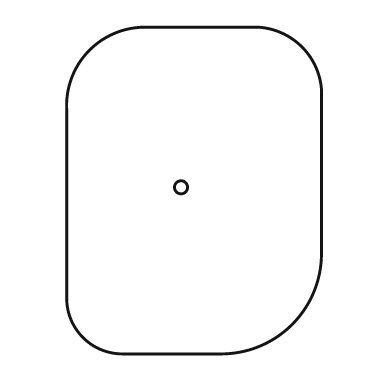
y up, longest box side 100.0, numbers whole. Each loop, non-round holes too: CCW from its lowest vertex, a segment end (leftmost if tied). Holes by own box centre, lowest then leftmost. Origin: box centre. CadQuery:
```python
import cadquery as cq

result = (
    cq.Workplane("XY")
    .moveTo(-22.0, -50.0)
    .lineTo(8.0, -50.0)
    .threePointArc((30.0, -41.0), (39.0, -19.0))
    .lineTo(39.0, 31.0)
    .threePointArc((33.0, 44.0), (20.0, 50.0))
    .lineTo(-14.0, 50.0)
    .threePointArc((-32.0, 43.0), (-39.0, 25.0))
    .lineTo(-39.0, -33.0)
    .threePointArc((-34.0, -45.0), (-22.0, -50.0))
    .close()
    .moveTo(-4.0, 1.0)
    .circle(2.0)
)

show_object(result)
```